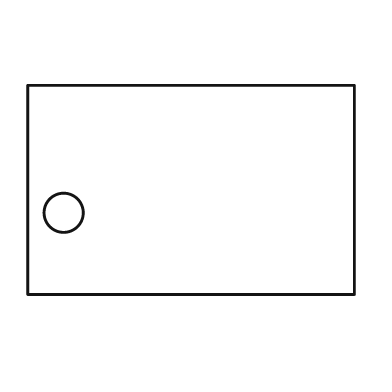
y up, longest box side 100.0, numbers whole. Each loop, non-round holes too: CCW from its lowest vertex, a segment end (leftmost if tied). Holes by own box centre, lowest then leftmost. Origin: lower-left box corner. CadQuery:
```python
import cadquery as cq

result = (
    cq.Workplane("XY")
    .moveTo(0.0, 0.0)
    .lineTo(100.0, 0.0)
    .lineTo(100.0, 64.0)
    .lineTo(0.0, 64.0)
    .close()
    .moveTo(11.0, 25.0)
    .circle(6.0)
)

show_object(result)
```